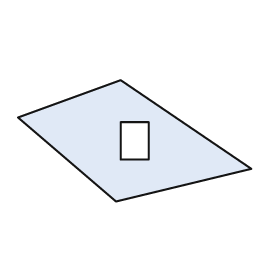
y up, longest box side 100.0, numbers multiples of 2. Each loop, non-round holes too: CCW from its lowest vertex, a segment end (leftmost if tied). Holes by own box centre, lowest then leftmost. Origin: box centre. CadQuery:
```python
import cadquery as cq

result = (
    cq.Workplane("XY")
    .moveTo(-8.0, -26.0)
    .lineTo(50.0, -12.0)
    .lineTo(-6.0, 26.0)
    .lineTo(-50.0, 10.0)
    .close()
    .moveTo(-6.0, -8.0)
    .lineTo(6.0, -8.0)
    .lineTo(6.0, 8.0)
    .lineTo(-6.0, 8.0)
    .close()
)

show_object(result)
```